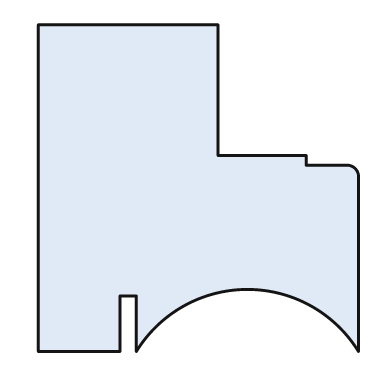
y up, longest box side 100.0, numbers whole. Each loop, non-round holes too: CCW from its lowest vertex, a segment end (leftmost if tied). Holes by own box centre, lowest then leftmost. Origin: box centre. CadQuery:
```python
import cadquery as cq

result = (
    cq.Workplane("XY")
    .moveTo(-49.0, -50.0)
    .lineTo(-24.0, -50.0)
    .lineTo(-24.0, -33.0)
    .lineTo(-19.0, -33.0)
    .lineTo(-19.0, -50.0)
    .threePointArc((15.0, -31.0), (49.0, -50.0))
    .lineTo(49.0, 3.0)
    .threePointArc((48.0, 6.0), (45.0, 7.0))
    .lineTo(33.0, 7.0)
    .lineTo(33.0, 10.0)
    .lineTo(6.0, 10.0)
    .lineTo(6.0, 50.0)
    .lineTo(-49.0, 50.0)
    .close()
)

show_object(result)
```